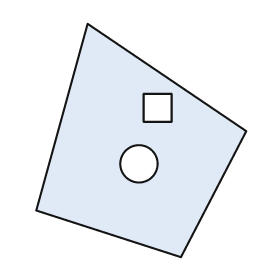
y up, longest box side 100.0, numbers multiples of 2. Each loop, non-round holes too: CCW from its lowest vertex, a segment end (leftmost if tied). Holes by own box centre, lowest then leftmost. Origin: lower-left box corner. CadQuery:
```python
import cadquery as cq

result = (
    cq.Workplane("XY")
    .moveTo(62.0, 0.0)
    .lineTo(90.0, 54.0)
    .lineTo(22.0, 100.0)
    .lineTo(0.0, 20.0)
    .close()
    .moveTo(44.0, 40.0)
    .circle(8.0)
    .moveTo(46.0, 58.0)
    .lineTo(58.0, 58.0)
    .lineTo(58.0, 70.0)
    .lineTo(46.0, 70.0)
    .close()
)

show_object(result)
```